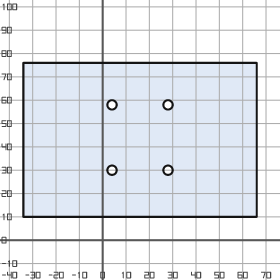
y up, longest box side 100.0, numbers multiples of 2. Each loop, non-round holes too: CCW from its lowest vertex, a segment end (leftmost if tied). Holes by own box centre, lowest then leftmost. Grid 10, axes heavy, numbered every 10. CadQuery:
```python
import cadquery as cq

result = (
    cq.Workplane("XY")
    .moveTo(-34.0, 10.0)
    .lineTo(66.0, 10.0)
    .lineTo(66.0, 76.0)
    .lineTo(-34.0, 76.0)
    .close()
    .moveTo(4.0, 30.0)
    .circle(2.0)
    .moveTo(28.0, 30.0)
    .circle(2.0)
    .moveTo(4.0, 58.0)
    .circle(2.0)
    .moveTo(28.0, 58.0)
    .circle(2.0)
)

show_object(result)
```